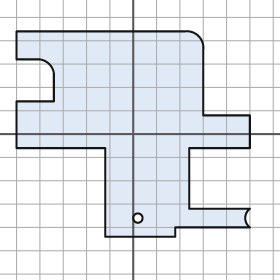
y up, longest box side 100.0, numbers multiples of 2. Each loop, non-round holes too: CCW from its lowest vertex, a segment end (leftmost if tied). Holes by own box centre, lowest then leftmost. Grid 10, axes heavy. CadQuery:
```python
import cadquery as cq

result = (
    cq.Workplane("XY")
    .moveTo(-12.0, -44.0)
    .lineTo(18.0, -44.0)
    .lineTo(18.0, -40.0)
    .lineTo(50.0, -40.0)
    .threePointArc((48.0, -36.0), (50.0, -32.0))
    .lineTo(24.0, -32.0)
    .lineTo(24.0, -6.0)
    .lineTo(50.0, -6.0)
    .lineTo(50.0, 8.0)
    .lineTo(30.0, 8.0)
    .lineTo(30.0, 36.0)
    .threePointArc((28.0, 42.0), (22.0, 44.0))
    .lineTo(-50.0, 44.0)
    .lineTo(-50.0, 32.0)
    .lineTo(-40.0, 32.0)
    .threePointArc((-36.0, 30.0), (-34.0, 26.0))
    .lineTo(-34.0, 14.0)
    .lineTo(-50.0, 14.0)
    .lineTo(-50.0, -6.0)
    .lineTo(-12.0, -6.0)
    .close()
    .moveTo(2.0, -36.0)
    .circle(2.0)
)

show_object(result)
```